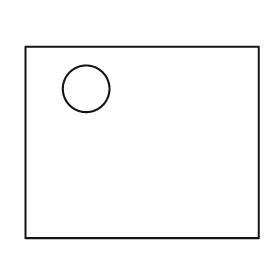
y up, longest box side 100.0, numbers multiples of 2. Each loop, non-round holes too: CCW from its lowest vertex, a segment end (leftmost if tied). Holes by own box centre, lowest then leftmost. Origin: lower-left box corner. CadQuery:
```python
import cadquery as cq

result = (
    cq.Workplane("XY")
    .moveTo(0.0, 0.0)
    .lineTo(100.0, 0.0)
    .lineTo(100.0, 82.0)
    .lineTo(0.0, 82.0)
    .close()
    .moveTo(26.0, 64.0)
    .circle(10.0)
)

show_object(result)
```